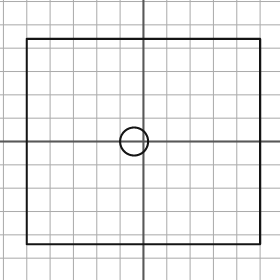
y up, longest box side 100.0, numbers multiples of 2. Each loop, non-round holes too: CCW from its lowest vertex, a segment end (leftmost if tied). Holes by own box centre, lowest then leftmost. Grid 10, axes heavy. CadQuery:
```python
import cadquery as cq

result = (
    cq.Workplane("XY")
    .moveTo(-50.0, -44.0)
    .lineTo(50.0, -44.0)
    .lineTo(50.0, 44.0)
    .lineTo(-50.0, 44.0)
    .close()
    .moveTo(-4.0, 0.0)
    .circle(6.0)
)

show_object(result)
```